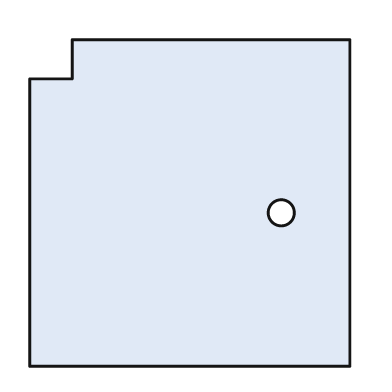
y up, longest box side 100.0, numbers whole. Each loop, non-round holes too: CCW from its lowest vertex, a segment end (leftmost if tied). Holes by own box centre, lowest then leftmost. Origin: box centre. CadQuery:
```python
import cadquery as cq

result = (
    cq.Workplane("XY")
    .moveTo(-49.0, -50.0)
    .lineTo(49.0, -50.0)
    .lineTo(49.0, 50.0)
    .lineTo(-36.0, 50.0)
    .lineTo(-36.0, 38.0)
    .lineTo(-49.0, 38.0)
    .close()
    .moveTo(28.0, -3.0)
    .circle(4.0)
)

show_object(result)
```